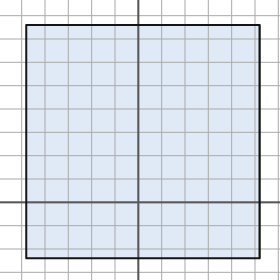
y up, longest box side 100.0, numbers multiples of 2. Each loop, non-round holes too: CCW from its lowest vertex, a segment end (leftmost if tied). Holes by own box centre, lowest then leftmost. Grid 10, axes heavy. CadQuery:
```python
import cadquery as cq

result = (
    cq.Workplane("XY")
    .moveTo(-48.0, -24.0)
    .lineTo(52.0, -24.0)
    .lineTo(52.0, 76.0)
    .lineTo(-48.0, 76.0)
    .close()
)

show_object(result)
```